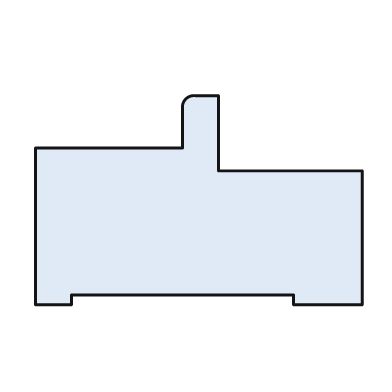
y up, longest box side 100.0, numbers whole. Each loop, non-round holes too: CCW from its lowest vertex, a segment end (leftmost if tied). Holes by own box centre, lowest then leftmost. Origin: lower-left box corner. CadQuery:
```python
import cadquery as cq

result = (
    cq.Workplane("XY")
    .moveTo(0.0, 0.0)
    .lineTo(11.0, 0.0)
    .lineTo(11.0, 3.0)
    .lineTo(79.0, 3.0)
    .lineTo(79.0, 0.0)
    .lineTo(100.0, 0.0)
    .lineTo(100.0, 41.0)
    .lineTo(56.0, 41.0)
    .lineTo(56.0, 64.0)
    .lineTo(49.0, 64.0)
    .threePointArc((46.0, 63.0), (45.0, 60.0))
    .lineTo(45.0, 48.0)
    .lineTo(0.0, 48.0)
    .close()
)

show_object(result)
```